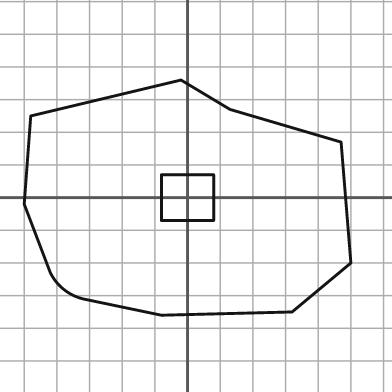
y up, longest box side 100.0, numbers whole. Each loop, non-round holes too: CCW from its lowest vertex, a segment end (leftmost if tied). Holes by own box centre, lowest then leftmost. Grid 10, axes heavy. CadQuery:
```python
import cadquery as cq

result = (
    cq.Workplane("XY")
    .moveTo(-8.0, -36.0)
    .lineTo(32.0, -35.0)
    .lineTo(50.0, -20.0)
    .lineTo(47.0, 17.0)
    .lineTo(13.0, 27.0)
    .lineTo(-2.0, 36.0)
    .lineTo(-48.0, 25.0)
    .lineTo(-50.0, -2.0)
    .lineTo(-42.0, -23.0)
    .threePointArc((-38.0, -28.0), (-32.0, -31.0))
    .close()
    .moveTo(-8.0, -7.0)
    .lineTo(8.0, -7.0)
    .lineTo(8.0, 7.0)
    .lineTo(-8.0, 7.0)
    .close()
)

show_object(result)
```